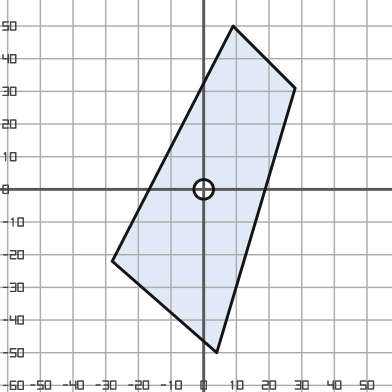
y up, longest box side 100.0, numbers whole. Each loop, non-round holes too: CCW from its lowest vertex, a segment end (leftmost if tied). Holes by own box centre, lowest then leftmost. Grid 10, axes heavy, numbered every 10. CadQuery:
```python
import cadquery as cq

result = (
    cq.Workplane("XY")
    .moveTo(4.0, -50.0)
    .lineTo(28.0, 31.0)
    .lineTo(9.0, 50.0)
    .lineTo(-28.0, -22.0)
    .close()
    .moveTo(0.0, 0.0)
    .circle(3.0)
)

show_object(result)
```